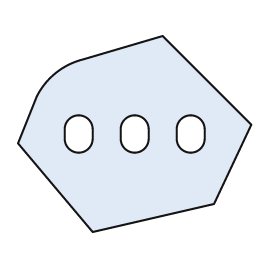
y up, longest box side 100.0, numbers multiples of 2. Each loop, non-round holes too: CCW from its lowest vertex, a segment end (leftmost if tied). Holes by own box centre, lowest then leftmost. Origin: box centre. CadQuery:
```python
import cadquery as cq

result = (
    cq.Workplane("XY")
    .moveTo(-18.0, -42.0)
    .lineTo(34.0, -30.0)
    .lineTo(50.0, 4.0)
    .lineTo(12.0, 42.0)
    .lineTo(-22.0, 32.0)
    .threePointArc((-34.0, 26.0), (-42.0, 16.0))
    .lineTo(-50.0, -4.0)
    .close()
    .moveTo(-30.0, -2.0)
    .threePointArc((-24.0, -8.0), (-18.0, -2.0))
    .lineTo(-18.0, 2.0)
    .threePointArc((-24.0, 8.0), (-30.0, 2.0))
    .close()
    .moveTo(-6.0, -2.0)
    .threePointArc((0.0, -8.0), (6.0, -2.0))
    .lineTo(6.0, 2.0)
    .threePointArc((0.0, 8.0), (-6.0, 2.0))
    .close()
    .moveTo(18.0, -2.0)
    .threePointArc((24.0, -8.0), (30.0, -2.0))
    .lineTo(30.0, 2.0)
    .threePointArc((24.0, 8.0), (18.0, 2.0))
    .close()
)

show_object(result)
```